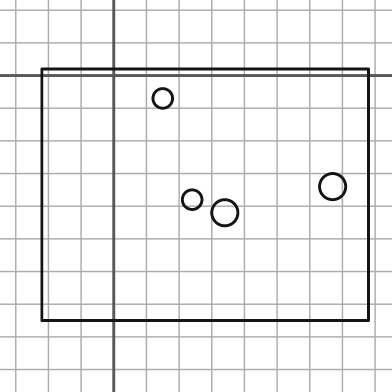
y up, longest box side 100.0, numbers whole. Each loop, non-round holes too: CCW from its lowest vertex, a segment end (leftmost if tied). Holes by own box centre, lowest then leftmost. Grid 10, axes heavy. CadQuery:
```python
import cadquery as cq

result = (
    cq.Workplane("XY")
    .moveTo(-22.0, -75.0)
    .lineTo(78.0, -75.0)
    .lineTo(78.0, 2.0)
    .lineTo(-22.0, 2.0)
    .close()
    .moveTo(34.0, -42.0)
    .circle(4.0)
    .moveTo(24.0, -38.0)
    .circle(3.0)
    .moveTo(67.0, -34.0)
    .circle(4.0)
    .moveTo(15.0, -7.0)
    .circle(3.0)
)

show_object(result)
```